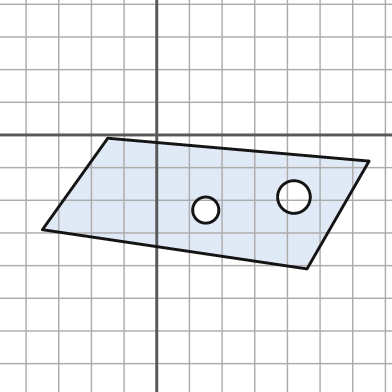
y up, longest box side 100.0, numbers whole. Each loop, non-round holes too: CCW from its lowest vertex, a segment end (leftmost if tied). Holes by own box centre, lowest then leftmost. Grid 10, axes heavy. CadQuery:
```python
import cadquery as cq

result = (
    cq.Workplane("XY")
    .moveTo(46.0, -41.0)
    .lineTo(65.0, -8.0)
    .lineTo(-15.0, -1.0)
    .lineTo(-35.0, -29.0)
    .close()
    .moveTo(15.0, -23.0)
    .circle(4.0)
    .moveTo(42.0, -19.0)
    .circle(5.0)
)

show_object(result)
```